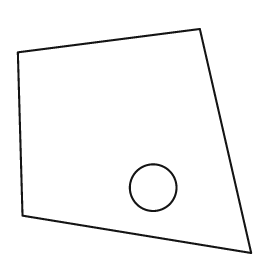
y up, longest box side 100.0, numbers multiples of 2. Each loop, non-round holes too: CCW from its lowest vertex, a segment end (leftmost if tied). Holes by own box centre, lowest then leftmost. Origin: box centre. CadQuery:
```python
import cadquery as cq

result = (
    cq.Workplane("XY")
    .moveTo(50.0, -48.0)
    .lineTo(28.0, 48.0)
    .lineTo(-50.0, 38.0)
    .lineTo(-48.0, -32.0)
    .close()
    .moveTo(8.0, -20.0)
    .circle(10.0)
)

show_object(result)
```